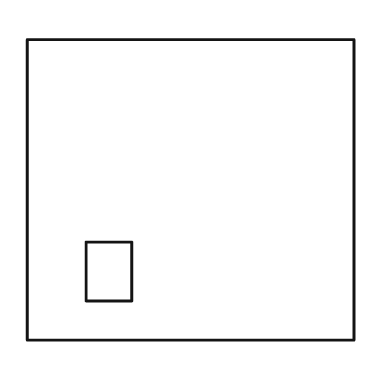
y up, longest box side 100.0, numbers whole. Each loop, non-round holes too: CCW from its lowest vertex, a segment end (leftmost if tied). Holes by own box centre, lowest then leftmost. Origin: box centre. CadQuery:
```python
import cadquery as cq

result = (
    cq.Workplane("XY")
    .moveTo(-50.0, -46.0)
    .lineTo(50.0, -46.0)
    .lineTo(50.0, 46.0)
    .lineTo(-50.0, 46.0)
    .close()
    .moveTo(-32.0, -34.0)
    .lineTo(-18.0, -34.0)
    .lineTo(-18.0, -16.0)
    .lineTo(-32.0, -16.0)
    .close()
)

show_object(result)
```